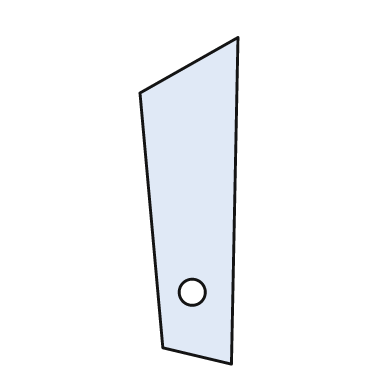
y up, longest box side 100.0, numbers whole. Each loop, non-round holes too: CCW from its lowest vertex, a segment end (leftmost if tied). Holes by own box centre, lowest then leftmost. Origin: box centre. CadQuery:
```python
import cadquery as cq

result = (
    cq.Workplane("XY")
    .moveTo(13.0, -50.0)
    .lineTo(15.0, 50.0)
    .lineTo(-15.0, 33.0)
    .lineTo(-8.0, -45.0)
    .close()
    .moveTo(1.0, -28.0)
    .circle(4.0)
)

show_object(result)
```